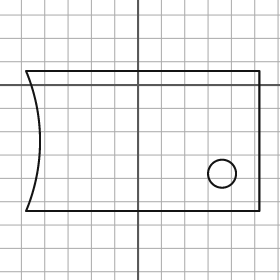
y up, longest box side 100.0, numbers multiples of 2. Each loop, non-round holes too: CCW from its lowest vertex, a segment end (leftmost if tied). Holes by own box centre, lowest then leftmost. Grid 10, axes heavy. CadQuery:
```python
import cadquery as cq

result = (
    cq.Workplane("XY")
    .moveTo(-48.0, -54.0)
    .lineTo(52.0, -54.0)
    .lineTo(52.0, 6.0)
    .lineTo(-48.0, 6.0)
    .threePointArc((-42.0, -24.0), (-48.0, -54.0))
    .close()
    .moveTo(36.0, -38.0)
    .circle(6.0)
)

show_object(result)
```